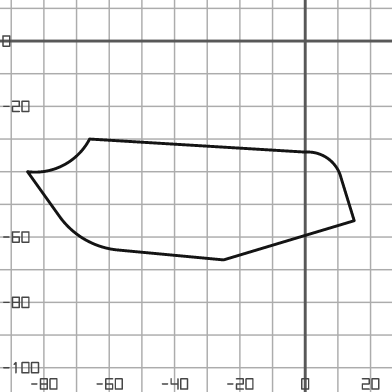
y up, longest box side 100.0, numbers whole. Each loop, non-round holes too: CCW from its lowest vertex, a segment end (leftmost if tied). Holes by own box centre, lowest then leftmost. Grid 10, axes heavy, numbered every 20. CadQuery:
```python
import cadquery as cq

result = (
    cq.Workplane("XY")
    .moveTo(-25.0, -67.0)
    .lineTo(15.0, -55.0)
    .lineTo(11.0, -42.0)
    .threePointArc((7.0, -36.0), (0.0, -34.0))
    .lineTo(-66.0, -30.0)
    .threePointArc((-74.0, -38.0), (-85.0, -40.0))
    .lineTo(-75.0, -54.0)
    .threePointArc((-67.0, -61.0), (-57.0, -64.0))
    .close()
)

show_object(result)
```